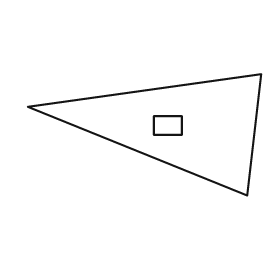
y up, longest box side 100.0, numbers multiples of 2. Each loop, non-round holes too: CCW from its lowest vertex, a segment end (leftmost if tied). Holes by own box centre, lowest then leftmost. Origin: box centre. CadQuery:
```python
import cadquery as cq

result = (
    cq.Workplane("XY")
    .moveTo(44.0, -26.0)
    .lineTo(50.0, 26.0)
    .lineTo(-50.0, 12.0)
    .close()
    .moveTo(4.0, 0.0)
    .lineTo(16.0, 0.0)
    .lineTo(16.0, 8.0)
    .lineTo(4.0, 8.0)
    .close()
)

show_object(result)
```